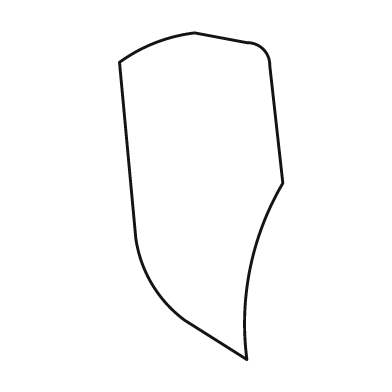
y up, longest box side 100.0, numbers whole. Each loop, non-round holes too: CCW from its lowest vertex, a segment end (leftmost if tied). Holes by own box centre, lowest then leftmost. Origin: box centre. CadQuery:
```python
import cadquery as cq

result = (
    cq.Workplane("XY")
    .moveTo(14.0, -50.0)
    .threePointArc((15.0, -22.0), (25.0, 4.0))
    .lineTo(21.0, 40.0)
    .threePointArc((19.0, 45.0), (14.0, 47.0))
    .lineTo(-2.0, 50.0)
    .threePointArc((-14.0, 47.0), (-25.0, 41.0))
    .lineTo(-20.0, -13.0)
    .threePointArc((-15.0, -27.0), (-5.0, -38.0))
    .close()
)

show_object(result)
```